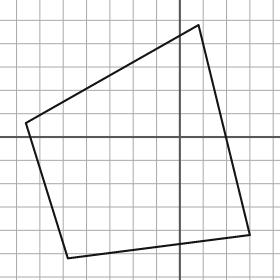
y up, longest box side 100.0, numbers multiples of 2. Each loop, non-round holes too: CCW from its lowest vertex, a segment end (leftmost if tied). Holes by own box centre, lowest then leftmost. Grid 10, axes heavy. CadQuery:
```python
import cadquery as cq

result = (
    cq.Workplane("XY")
    .moveTo(-48.0, -52.0)
    .lineTo(30.0, -42.0)
    .lineTo(8.0, 48.0)
    .lineTo(-66.0, 6.0)
    .close()
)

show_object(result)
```